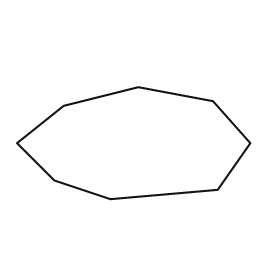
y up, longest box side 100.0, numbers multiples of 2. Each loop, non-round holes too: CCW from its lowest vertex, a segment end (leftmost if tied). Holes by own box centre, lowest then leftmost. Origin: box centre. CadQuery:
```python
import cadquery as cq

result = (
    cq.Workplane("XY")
    .moveTo(-10.0, -24.0)
    .lineTo(36.0, -20.0)
    .lineTo(50.0, 0.0)
    .lineTo(34.0, 18.0)
    .lineTo(2.0, 24.0)
    .lineTo(-30.0, 16.0)
    .lineTo(-50.0, 0.0)
    .lineTo(-34.0, -16.0)
    .close()
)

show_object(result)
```